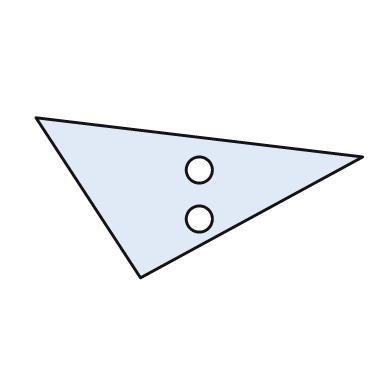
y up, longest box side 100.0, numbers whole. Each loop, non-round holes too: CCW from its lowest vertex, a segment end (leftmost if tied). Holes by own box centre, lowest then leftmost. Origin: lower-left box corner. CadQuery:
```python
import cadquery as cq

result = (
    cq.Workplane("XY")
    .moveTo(32.0, 0.0)
    .lineTo(100.0, 37.0)
    .lineTo(0.0, 49.0)
    .close()
    .moveTo(50.0, 18.0)
    .circle(4.0)
    .moveTo(50.0, 33.0)
    .circle(4.0)
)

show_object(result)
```